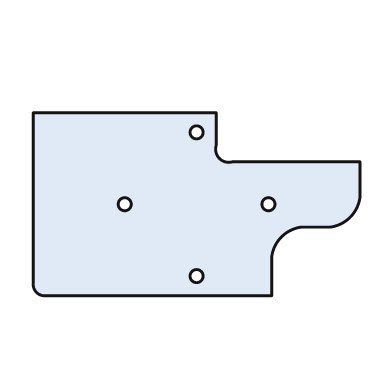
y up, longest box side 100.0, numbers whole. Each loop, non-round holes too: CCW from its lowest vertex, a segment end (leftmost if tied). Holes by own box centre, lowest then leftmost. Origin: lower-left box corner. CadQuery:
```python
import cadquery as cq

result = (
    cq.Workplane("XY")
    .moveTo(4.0, 0.0)
    .lineTo(73.0, 0.0)
    .lineTo(73.0, 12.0)
    .threePointArc((76.0, 18.0), (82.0, 21.0))
    .lineTo(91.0, 21.0)
    .threePointArc((97.0, 24.0), (100.0, 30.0))
    .lineTo(100.0, 41.0)
    .lineTo(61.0, 41.0)
    .threePointArc((57.0, 42.0), (56.0, 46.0))
    .lineTo(56.0, 56.0)
    .lineTo(0.0, 56.0)
    .lineTo(0.0, 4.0)
    .threePointArc((1.0, 1.0), (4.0, 0.0))
    .close()
    .moveTo(50.0, 6.0)
    .circle(2.0)
    .moveTo(28.0, 28.0)
    .circle(2.0)
    .moveTo(72.0, 28.0)
    .circle(2.0)
    .moveTo(50.0, 50.0)
    .circle(2.0)
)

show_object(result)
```